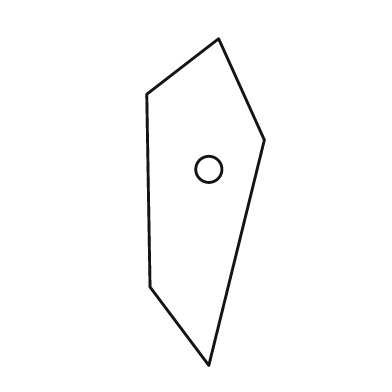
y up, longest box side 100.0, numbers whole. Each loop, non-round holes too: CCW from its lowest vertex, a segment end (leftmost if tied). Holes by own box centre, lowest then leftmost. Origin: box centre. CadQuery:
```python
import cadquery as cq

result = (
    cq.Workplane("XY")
    .moveTo(1.0, -50.0)
    .lineTo(18.0, 19.0)
    .lineTo(4.0, 50.0)
    .lineTo(-18.0, 33.0)
    .lineTo(-17.0, -26.0)
    .close()
    .moveTo(1.0, 10.0)
    .circle(4.0)
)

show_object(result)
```